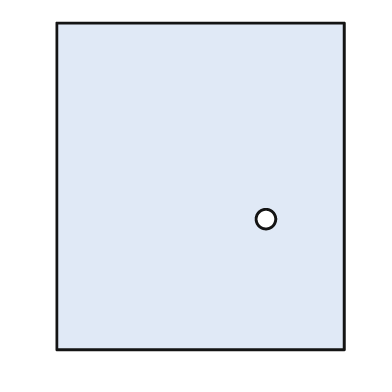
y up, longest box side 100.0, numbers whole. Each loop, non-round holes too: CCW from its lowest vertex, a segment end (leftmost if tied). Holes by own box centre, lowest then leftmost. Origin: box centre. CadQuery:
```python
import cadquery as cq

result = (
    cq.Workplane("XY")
    .moveTo(-44.0, -50.0)
    .lineTo(44.0, -50.0)
    .lineTo(44.0, 50.0)
    .lineTo(-44.0, 50.0)
    .close()
    .moveTo(20.0, -10.0)
    .circle(3.0)
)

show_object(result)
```